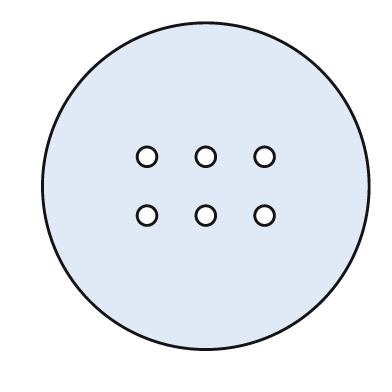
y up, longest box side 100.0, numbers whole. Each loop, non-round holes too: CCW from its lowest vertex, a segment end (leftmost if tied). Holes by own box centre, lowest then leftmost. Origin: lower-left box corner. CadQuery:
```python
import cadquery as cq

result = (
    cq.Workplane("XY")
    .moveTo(50.0, 50.0)
    .circle(50.0)
    .moveTo(32.0, 41.0)
    .circle(3.0)
    .moveTo(50.0, 41.0)
    .circle(3.0)
    .moveTo(68.0, 41.0)
    .circle(3.0)
    .moveTo(32.0, 59.0)
    .circle(3.0)
    .moveTo(50.0, 59.0)
    .circle(3.0)
    .moveTo(68.0, 59.0)
    .circle(3.0)
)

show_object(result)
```